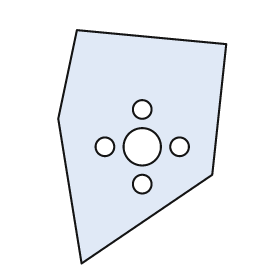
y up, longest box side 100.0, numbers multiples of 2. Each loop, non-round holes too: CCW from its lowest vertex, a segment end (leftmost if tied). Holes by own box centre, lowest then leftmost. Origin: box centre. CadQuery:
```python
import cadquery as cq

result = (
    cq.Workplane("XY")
    .moveTo(-26.0, -50.0)
    .lineTo(30.0, -12.0)
    .lineTo(36.0, 44.0)
    .lineTo(-28.0, 50.0)
    .lineTo(-36.0, 12.0)
    .close()
    .moveTo(0.0, -16.0)
    .circle(4.0)
    .moveTo(-16.0, 0.0)
    .circle(4.0)
    .moveTo(0.0, 0.0)
    .circle(8.0)
    .moveTo(16.0, 0.0)
    .circle(4.0)
    .moveTo(0.0, 16.0)
    .circle(4.0)
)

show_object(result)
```